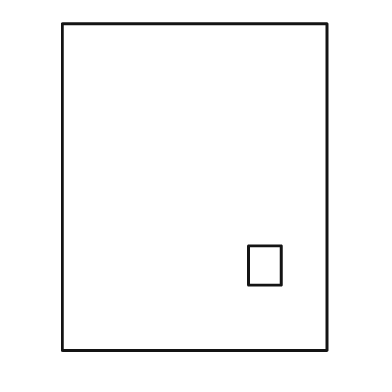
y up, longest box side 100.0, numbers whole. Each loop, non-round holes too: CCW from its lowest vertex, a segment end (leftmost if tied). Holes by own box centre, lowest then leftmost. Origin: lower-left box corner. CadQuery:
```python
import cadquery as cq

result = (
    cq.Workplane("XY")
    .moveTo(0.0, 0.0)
    .lineTo(81.0, 0.0)
    .lineTo(81.0, 100.0)
    .lineTo(0.0, 100.0)
    .close()
    .moveTo(57.0, 20.0)
    .lineTo(67.0, 20.0)
    .lineTo(67.0, 32.0)
    .lineTo(57.0, 32.0)
    .close()
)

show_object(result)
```